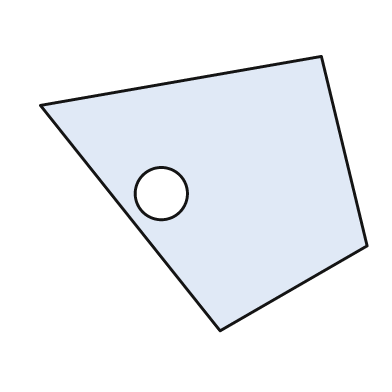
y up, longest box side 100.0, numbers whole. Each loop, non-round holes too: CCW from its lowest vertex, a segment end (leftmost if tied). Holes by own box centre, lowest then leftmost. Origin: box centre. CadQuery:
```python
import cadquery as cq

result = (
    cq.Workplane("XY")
    .moveTo(5.0, -42.0)
    .lineTo(50.0, -16.0)
    .lineTo(36.0, 42.0)
    .lineTo(-50.0, 27.0)
    .close()
    .moveTo(-13.0, 0.0)
    .circle(8.0)
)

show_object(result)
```